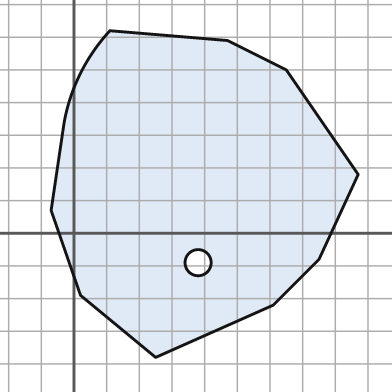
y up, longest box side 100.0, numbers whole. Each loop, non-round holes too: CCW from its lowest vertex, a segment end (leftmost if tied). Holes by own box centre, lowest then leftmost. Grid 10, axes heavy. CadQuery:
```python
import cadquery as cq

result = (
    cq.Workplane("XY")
    .moveTo(25.0, -38.0)
    .lineTo(61.0, -22.0)
    .lineTo(75.0, -8.0)
    .lineTo(87.0, 18.0)
    .lineTo(65.0, 50.0)
    .lineTo(47.0, 59.0)
    .lineTo(11.0, 62.0)
    .threePointArc((2.0, 49.0), (-3.0, 34.0))
    .lineTo(-7.0, 7.0)
    .lineTo(2.0, -19.0)
    .close()
    .moveTo(38.0, -9.0)
    .circle(4.0)
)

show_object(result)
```